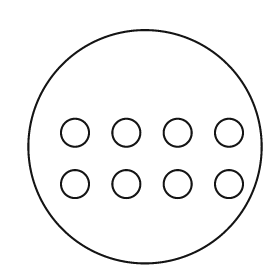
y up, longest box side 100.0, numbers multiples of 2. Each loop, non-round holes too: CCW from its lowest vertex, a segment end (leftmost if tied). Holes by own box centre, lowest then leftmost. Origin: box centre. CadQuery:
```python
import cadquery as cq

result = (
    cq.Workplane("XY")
    .moveTo(0.0, 0.0)
    .circle(50.0)
    .moveTo(-30.0, -16.0)
    .circle(6.0)
    .moveTo(-8.0, -16.0)
    .circle(6.0)
    .moveTo(14.0, -16.0)
    .circle(6.0)
    .moveTo(36.0, -16.0)
    .circle(6.0)
    .moveTo(-30.0, 6.0)
    .circle(6.0)
    .moveTo(-8.0, 6.0)
    .circle(6.0)
    .moveTo(14.0, 6.0)
    .circle(6.0)
    .moveTo(36.0, 6.0)
    .circle(6.0)
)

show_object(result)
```